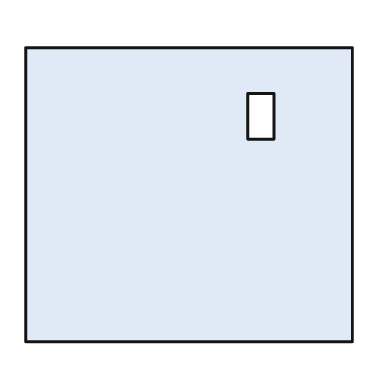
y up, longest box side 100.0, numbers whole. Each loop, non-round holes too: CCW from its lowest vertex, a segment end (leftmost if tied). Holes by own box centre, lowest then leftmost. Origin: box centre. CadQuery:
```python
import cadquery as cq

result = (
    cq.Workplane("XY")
    .moveTo(-50.0, -45.0)
    .lineTo(50.0, -45.0)
    .lineTo(50.0, 45.0)
    .lineTo(-50.0, 45.0)
    .close()
    .moveTo(18.0, 17.0)
    .lineTo(26.0, 17.0)
    .lineTo(26.0, 31.0)
    .lineTo(18.0, 31.0)
    .close()
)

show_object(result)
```